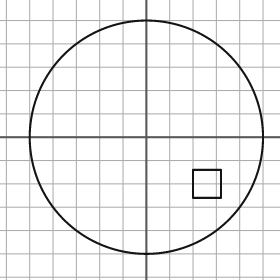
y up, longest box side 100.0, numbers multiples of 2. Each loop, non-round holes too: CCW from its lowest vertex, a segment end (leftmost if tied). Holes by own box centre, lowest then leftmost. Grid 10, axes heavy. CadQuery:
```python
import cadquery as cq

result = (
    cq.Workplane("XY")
    .moveTo(0.0, 0.0)
    .circle(50.0)
    .moveTo(20.0, -26.0)
    .lineTo(32.0, -26.0)
    .lineTo(32.0, -14.0)
    .lineTo(20.0, -14.0)
    .close()
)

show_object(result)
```